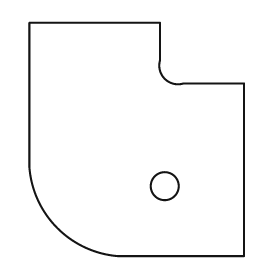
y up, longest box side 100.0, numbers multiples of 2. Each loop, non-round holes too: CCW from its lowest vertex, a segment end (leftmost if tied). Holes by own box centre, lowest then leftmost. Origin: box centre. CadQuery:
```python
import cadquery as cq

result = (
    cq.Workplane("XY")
    .moveTo(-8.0, -50.0)
    .lineTo(46.0, -50.0)
    .lineTo(46.0, 24.0)
    .lineTo(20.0, 24.0)
    .threePointArc((12.0, 26.0), (10.0, 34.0))
    .lineTo(10.0, 50.0)
    .lineTo(-46.0, 50.0)
    .lineTo(-46.0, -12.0)
    .threePointArc((-34.0, -38.0), (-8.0, -50.0))
    .close()
    .moveTo(12.0, -20.0)
    .circle(6.0)
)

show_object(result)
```